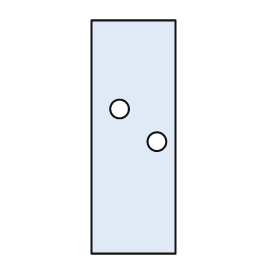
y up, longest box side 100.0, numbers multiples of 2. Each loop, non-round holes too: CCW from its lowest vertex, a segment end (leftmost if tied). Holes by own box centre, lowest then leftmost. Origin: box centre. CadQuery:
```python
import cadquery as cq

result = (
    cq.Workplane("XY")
    .moveTo(-18.0, -50.0)
    .lineTo(18.0, -50.0)
    .lineTo(18.0, 50.0)
    .lineTo(-18.0, 50.0)
    .close()
    .moveTo(10.0, -2.0)
    .circle(4.0)
    .moveTo(-6.0, 12.0)
    .circle(4.0)
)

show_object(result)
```